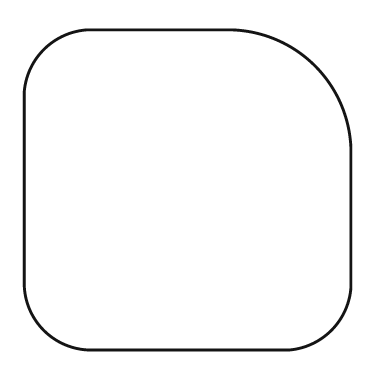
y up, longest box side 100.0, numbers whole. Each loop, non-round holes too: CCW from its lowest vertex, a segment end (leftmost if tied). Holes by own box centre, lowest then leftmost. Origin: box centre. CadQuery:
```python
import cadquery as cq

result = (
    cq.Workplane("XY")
    .moveTo(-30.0, -49.0)
    .lineTo(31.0, -49.0)
    .threePointArc((44.0, -43.0), (50.0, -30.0))
    .lineTo(50.0, 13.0)
    .threePointArc((39.0, 38.0), (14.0, 49.0))
    .lineTo(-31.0, 49.0)
    .threePointArc((-44.0, 43.0), (-50.0, 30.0))
    .lineTo(-50.0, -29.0)
    .threePointArc((-44.0, -43.0), (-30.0, -49.0))
    .close()
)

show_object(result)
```